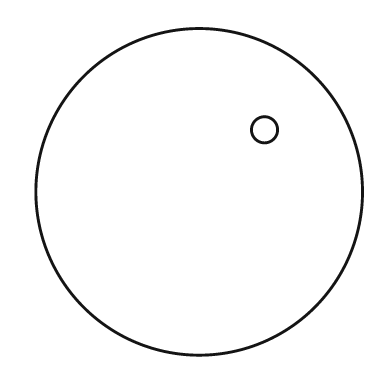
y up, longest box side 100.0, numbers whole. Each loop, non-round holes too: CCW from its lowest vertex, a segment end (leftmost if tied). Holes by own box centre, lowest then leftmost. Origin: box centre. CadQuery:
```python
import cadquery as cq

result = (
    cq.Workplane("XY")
    .moveTo(0.0, 0.0)
    .circle(50.0)
    .moveTo(20.0, 19.0)
    .circle(4.0)
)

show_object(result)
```